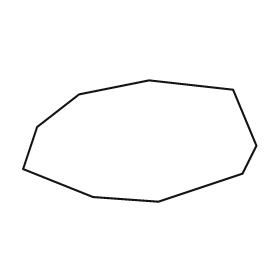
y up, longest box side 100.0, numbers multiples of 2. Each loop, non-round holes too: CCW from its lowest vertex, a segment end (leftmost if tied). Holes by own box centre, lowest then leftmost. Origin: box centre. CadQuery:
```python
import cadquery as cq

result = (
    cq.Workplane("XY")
    .moveTo(8.0, -26.0)
    .lineTo(44.0, -14.0)
    .lineTo(50.0, -2.0)
    .lineTo(40.0, 22.0)
    .lineTo(4.0, 26.0)
    .lineTo(-26.0, 20.0)
    .lineTo(-44.0, 6.0)
    .lineTo(-50.0, -12.0)
    .lineTo(-20.0, -24.0)
    .close()
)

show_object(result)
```